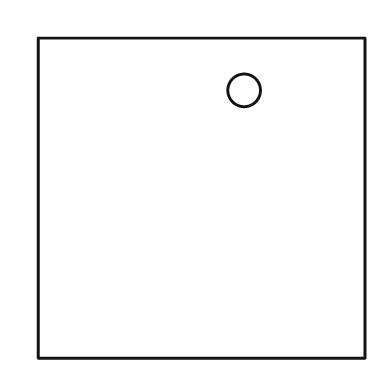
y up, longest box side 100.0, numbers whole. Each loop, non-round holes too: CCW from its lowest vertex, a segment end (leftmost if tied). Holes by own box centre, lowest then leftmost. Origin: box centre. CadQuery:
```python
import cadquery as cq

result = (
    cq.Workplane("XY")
    .moveTo(-50.0, -49.0)
    .lineTo(50.0, -49.0)
    .lineTo(50.0, 49.0)
    .lineTo(-50.0, 49.0)
    .close()
    .moveTo(13.0, 33.0)
    .circle(5.0)
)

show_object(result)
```